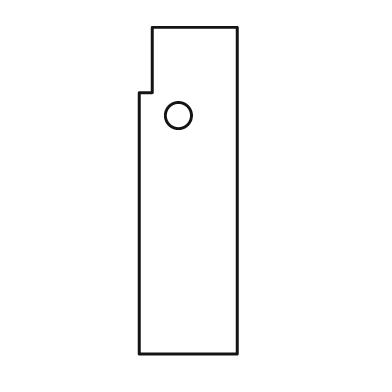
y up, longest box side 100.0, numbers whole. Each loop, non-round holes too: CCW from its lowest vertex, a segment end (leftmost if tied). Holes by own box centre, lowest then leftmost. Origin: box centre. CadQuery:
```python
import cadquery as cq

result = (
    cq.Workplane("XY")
    .moveTo(-15.0, -50.0)
    .lineTo(15.0, -50.0)
    .lineTo(15.0, 50.0)
    .lineTo(-11.0, 50.0)
    .lineTo(-11.0, 30.0)
    .lineTo(-15.0, 30.0)
    .close()
    .moveTo(-3.0, 23.0)
    .circle(4.0)
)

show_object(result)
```